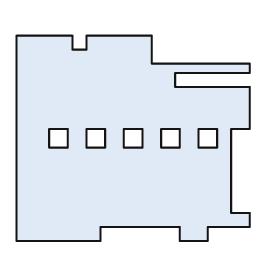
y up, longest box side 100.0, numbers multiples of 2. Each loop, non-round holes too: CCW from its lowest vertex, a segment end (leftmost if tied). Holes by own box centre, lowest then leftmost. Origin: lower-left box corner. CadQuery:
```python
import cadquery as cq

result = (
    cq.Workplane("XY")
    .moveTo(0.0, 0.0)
    .lineTo(36.0, 0.0)
    .lineTo(36.0, 6.0)
    .lineTo(70.0, 6.0)
    .lineTo(70.0, 0.0)
    .lineTo(82.0, 0.0)
    .lineTo(82.0, 6.0)
    .lineTo(100.0, 6.0)
    .lineTo(100.0, 12.0)
    .lineTo(92.0, 12.0)
    .lineTo(92.0, 48.0)
    .lineTo(100.0, 48.0)
    .lineTo(100.0, 66.0)
    .lineTo(68.0, 66.0)
    .lineTo(68.0, 72.0)
    .lineTo(100.0, 72.0)
    .lineTo(100.0, 76.0)
    .lineTo(58.0, 76.0)
    .lineTo(58.0, 88.0)
    .lineTo(30.0, 88.0)
    .lineTo(30.0, 82.0)
    .lineTo(24.0, 82.0)
    .lineTo(24.0, 88.0)
    .lineTo(0.0, 88.0)
    .close()
    .moveTo(14.0, 40.0)
    .lineTo(22.0, 40.0)
    .lineTo(22.0, 48.0)
    .lineTo(14.0, 48.0)
    .close()
    .moveTo(30.0, 40.0)
    .lineTo(38.0, 40.0)
    .lineTo(38.0, 48.0)
    .lineTo(30.0, 48.0)
    .close()
    .moveTo(46.0, 40.0)
    .lineTo(54.0, 40.0)
    .lineTo(54.0, 48.0)
    .lineTo(46.0, 48.0)
    .close()
    .moveTo(62.0, 40.0)
    .lineTo(70.0, 40.0)
    .lineTo(70.0, 48.0)
    .lineTo(62.0, 48.0)
    .close()
    .moveTo(78.0, 40.0)
    .lineTo(86.0, 40.0)
    .lineTo(86.0, 48.0)
    .lineTo(78.0, 48.0)
    .close()
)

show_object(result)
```